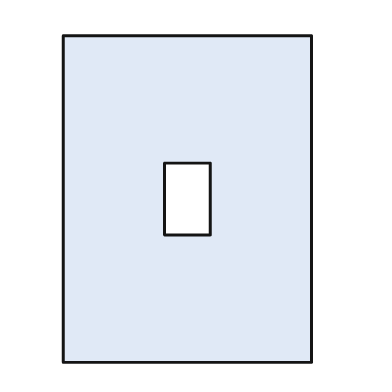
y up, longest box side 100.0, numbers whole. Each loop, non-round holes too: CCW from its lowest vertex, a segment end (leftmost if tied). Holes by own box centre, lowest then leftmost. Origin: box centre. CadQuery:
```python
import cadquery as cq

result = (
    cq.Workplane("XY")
    .moveTo(-38.0, -50.0)
    .lineTo(38.0, -50.0)
    .lineTo(38.0, 50.0)
    .lineTo(-38.0, 50.0)
    .close()
    .moveTo(-7.0, -11.0)
    .lineTo(7.0, -11.0)
    .lineTo(7.0, 11.0)
    .lineTo(-7.0, 11.0)
    .close()
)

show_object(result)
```